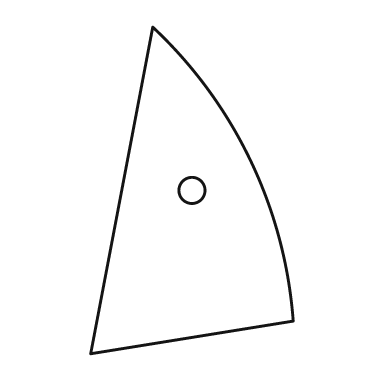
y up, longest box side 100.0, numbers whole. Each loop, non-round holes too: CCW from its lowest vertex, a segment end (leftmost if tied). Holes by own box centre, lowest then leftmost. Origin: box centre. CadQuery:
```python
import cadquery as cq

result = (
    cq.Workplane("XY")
    .moveTo(-31.0, -50.0)
    .lineTo(31.0, -40.0)
    .threePointArc((18.0, 9.0), (-12.0, 50.0))
    .close()
    .moveTo(0.0, 0.0)
    .circle(4.0)
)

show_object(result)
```